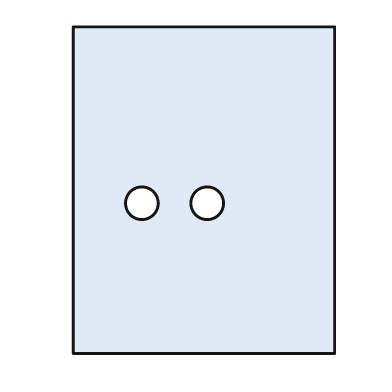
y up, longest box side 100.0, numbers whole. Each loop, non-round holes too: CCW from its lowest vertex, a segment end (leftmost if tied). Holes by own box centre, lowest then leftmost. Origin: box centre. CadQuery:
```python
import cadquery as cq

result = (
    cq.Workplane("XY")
    .moveTo(-40.0, -50.0)
    .lineTo(40.0, -50.0)
    .lineTo(40.0, 50.0)
    .lineTo(-40.0, 50.0)
    .close()
    .moveTo(-19.0, -4.0)
    .circle(5.0)
    .moveTo(1.0, -4.0)
    .circle(5.0)
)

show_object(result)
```